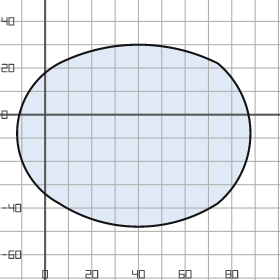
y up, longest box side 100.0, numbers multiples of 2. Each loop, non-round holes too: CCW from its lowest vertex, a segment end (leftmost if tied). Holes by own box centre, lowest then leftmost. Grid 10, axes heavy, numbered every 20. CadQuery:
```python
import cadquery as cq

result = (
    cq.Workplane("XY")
    .moveTo(6.0, -38.0)
    .threePointArc((40.0, -48.0), (74.0, -38.0))
    .threePointArc((88.0, -8.0), (74.0, 22.0))
    .threePointArc((40.0, 30.0), (6.0, 22.0))
    .threePointArc((-12.0, -8.0), (6.0, -38.0))
    .close()
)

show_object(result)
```